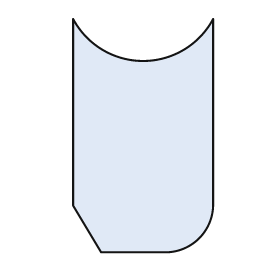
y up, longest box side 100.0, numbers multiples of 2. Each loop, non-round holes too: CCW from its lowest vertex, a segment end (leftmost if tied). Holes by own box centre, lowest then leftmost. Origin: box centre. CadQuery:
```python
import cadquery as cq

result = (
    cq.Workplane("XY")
    .moveTo(-18.0, -50.0)
    .lineTo(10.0, -50.0)
    .threePointArc((24.0, -44.0), (30.0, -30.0))
    .lineTo(30.0, 50.0)
    .threePointArc((0.0, 32.0), (-30.0, 50.0))
    .lineTo(-30.0, -30.0)
    .close()
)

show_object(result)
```